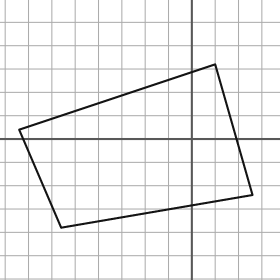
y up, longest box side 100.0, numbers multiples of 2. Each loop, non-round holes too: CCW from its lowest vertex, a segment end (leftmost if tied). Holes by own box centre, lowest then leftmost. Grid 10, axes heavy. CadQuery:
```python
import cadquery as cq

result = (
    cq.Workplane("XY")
    .moveTo(-56.0, -38.0)
    .lineTo(26.0, -24.0)
    .lineTo(10.0, 32.0)
    .lineTo(-74.0, 4.0)
    .close()
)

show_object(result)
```